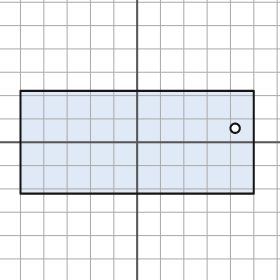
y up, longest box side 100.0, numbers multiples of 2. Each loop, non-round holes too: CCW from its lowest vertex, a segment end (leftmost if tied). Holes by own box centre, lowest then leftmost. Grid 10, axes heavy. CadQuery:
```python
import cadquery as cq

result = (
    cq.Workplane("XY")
    .moveTo(-50.0, -22.0)
    .lineTo(50.0, -22.0)
    .lineTo(50.0, 22.0)
    .lineTo(-50.0, 22.0)
    .close()
    .moveTo(42.0, 6.0)
    .circle(2.0)
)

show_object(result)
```